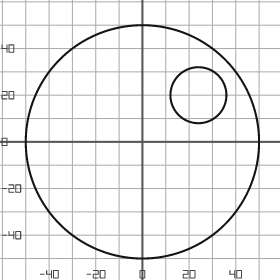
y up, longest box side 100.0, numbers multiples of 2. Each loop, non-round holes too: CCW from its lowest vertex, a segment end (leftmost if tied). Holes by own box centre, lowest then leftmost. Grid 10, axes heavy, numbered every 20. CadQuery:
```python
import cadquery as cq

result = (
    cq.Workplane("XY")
    .moveTo(0.0, 0.0)
    .circle(50.0)
    .moveTo(24.0, 20.0)
    .circle(12.0)
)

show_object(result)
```